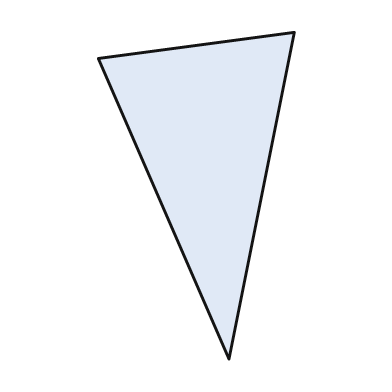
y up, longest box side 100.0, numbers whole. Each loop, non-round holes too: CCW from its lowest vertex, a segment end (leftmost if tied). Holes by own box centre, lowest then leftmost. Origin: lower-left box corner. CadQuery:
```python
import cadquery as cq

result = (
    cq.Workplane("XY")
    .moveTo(40.0, 0.0)
    .lineTo(60.0, 100.0)
    .lineTo(0.0, 92.0)
    .close()
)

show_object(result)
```